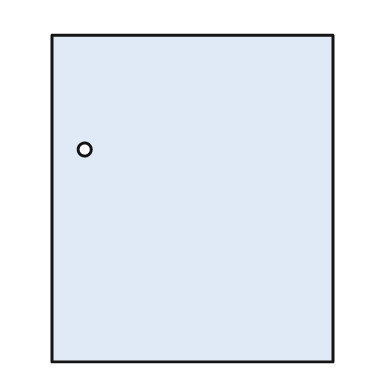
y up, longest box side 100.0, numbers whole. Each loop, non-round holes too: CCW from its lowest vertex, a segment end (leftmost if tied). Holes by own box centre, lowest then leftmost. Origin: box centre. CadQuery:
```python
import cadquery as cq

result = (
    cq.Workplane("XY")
    .moveTo(-43.0, -50.0)
    .lineTo(43.0, -50.0)
    .lineTo(43.0, 50.0)
    .lineTo(-43.0, 50.0)
    .close()
    .moveTo(-33.0, 15.0)
    .circle(2.0)
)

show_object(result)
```